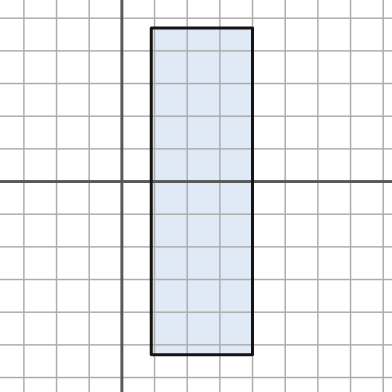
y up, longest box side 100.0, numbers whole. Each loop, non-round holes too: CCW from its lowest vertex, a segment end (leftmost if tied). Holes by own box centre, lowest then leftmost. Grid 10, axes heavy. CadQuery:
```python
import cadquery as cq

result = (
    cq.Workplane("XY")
    .moveTo(9.0, -53.0)
    .lineTo(40.0, -53.0)
    .lineTo(40.0, 47.0)
    .lineTo(9.0, 47.0)
    .close()
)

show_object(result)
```